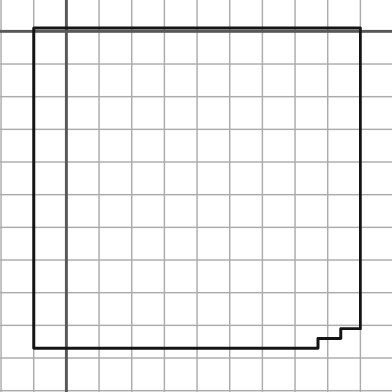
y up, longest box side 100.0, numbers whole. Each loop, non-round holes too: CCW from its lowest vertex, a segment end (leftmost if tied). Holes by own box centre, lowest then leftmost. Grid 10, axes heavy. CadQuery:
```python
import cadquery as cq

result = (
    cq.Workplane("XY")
    .moveTo(-10.0, -97.0)
    .lineTo(77.0, -97.0)
    .lineTo(77.0, -94.0)
    .lineTo(84.0, -94.0)
    .lineTo(84.0, -91.0)
    .lineTo(90.0, -91.0)
    .lineTo(90.0, 1.0)
    .lineTo(-10.0, 1.0)
    .close()
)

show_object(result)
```